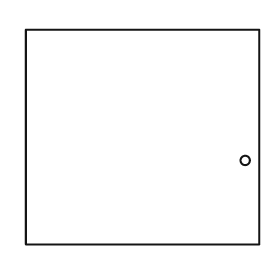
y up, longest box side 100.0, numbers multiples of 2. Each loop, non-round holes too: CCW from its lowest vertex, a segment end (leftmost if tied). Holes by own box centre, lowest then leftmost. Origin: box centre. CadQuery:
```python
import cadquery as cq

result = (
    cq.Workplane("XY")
    .moveTo(-50.0, -46.0)
    .lineTo(50.0, -46.0)
    .lineTo(50.0, 46.0)
    .lineTo(-50.0, 46.0)
    .close()
    .moveTo(44.0, -10.0)
    .circle(2.0)
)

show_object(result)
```